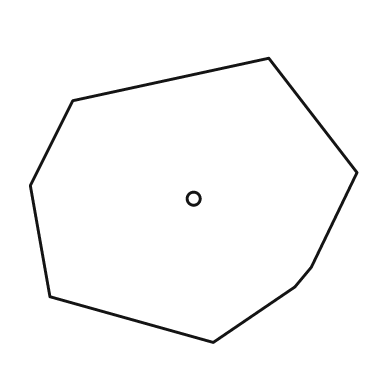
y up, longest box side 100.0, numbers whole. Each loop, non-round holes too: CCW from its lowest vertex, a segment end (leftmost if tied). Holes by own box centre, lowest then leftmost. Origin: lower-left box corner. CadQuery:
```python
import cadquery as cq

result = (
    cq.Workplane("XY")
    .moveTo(56.0, 0.0)
    .lineTo(81.0, 17.0)
    .lineTo(86.0, 23.0)
    .lineTo(100.0, 52.0)
    .lineTo(73.0, 87.0)
    .lineTo(13.0, 74.0)
    .lineTo(0.0, 48.0)
    .lineTo(6.0, 14.0)
    .close()
    .moveTo(50.0, 44.0)
    .circle(2.0)
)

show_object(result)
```